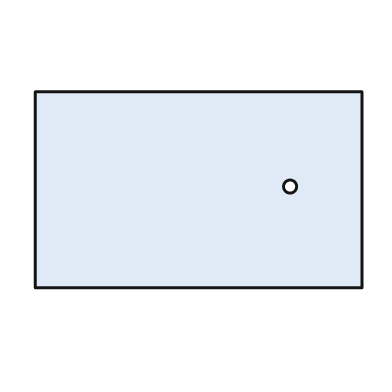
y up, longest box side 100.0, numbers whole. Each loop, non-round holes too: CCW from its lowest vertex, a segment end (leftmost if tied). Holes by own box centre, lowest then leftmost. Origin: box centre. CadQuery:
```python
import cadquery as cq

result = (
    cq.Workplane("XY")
    .moveTo(-50.0, -30.0)
    .lineTo(50.0, -30.0)
    .lineTo(50.0, 30.0)
    .lineTo(-50.0, 30.0)
    .close()
    .moveTo(28.0, 1.0)
    .circle(2.0)
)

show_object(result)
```